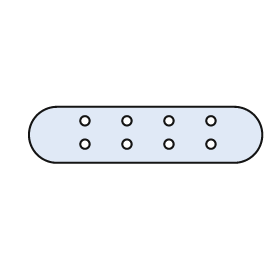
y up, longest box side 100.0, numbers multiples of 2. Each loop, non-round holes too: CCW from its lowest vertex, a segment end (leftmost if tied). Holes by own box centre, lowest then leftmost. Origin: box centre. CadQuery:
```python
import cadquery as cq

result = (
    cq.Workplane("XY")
    .moveTo(-38.0, -12.0)
    .lineTo(38.0, -12.0)
    .threePointArc((50.0, 0.0), (38.0, 12.0))
    .lineTo(-38.0, 12.0)
    .threePointArc((-50.0, 0.0), (-38.0, -12.0))
    .close()
    .moveTo(-26.0, -4.0)
    .circle(2.0)
    .moveTo(-8.0, -4.0)
    .circle(2.0)
    .moveTo(10.0, -4.0)
    .circle(2.0)
    .moveTo(28.0, -4.0)
    .circle(2.0)
    .moveTo(-26.0, 6.0)
    .circle(2.0)
    .moveTo(-8.0, 6.0)
    .circle(2.0)
    .moveTo(10.0, 6.0)
    .circle(2.0)
    .moveTo(28.0, 6.0)
    .circle(2.0)
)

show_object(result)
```